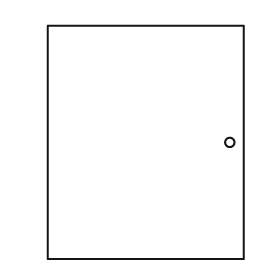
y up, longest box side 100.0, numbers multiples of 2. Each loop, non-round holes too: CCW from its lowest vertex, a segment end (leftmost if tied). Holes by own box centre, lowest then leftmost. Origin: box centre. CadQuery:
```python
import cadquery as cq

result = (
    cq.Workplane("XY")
    .moveTo(-42.0, -50.0)
    .lineTo(42.0, -50.0)
    .lineTo(42.0, 50.0)
    .lineTo(-42.0, 50.0)
    .close()
    .moveTo(36.0, 0.0)
    .circle(2.0)
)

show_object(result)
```